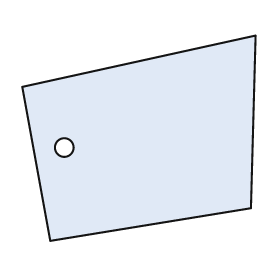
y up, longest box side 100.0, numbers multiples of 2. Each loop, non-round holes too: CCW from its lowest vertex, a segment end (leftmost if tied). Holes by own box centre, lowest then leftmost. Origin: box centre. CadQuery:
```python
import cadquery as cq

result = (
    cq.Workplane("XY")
    .moveTo(-38.0, -44.0)
    .lineTo(48.0, -30.0)
    .lineTo(50.0, 44.0)
    .lineTo(-50.0, 22.0)
    .close()
    .moveTo(-32.0, -4.0)
    .circle(4.0)
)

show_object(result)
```